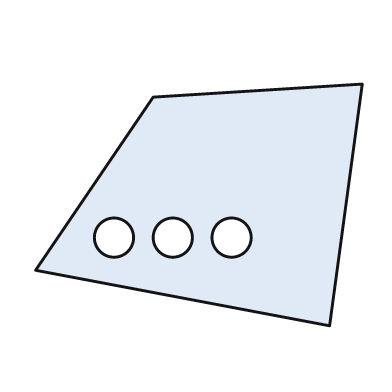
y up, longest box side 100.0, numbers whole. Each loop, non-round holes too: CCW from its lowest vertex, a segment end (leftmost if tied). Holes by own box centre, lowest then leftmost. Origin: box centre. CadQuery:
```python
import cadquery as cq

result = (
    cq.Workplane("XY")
    .moveTo(40.0, -37.0)
    .lineTo(50.0, 37.0)
    .lineTo(-14.0, 33.0)
    .lineTo(-50.0, -20.0)
    .close()
    .moveTo(-26.0, -10.0)
    .circle(6.0)
    .moveTo(-8.0, -10.0)
    .circle(6.0)
    .moveTo(10.0, -10.0)
    .circle(6.0)
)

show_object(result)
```